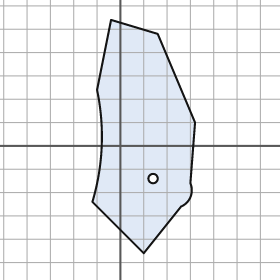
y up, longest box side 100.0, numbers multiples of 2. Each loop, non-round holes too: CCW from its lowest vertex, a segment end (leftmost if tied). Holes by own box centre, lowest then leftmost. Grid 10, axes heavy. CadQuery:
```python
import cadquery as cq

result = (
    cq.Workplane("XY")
    .moveTo(10.0, -46.0)
    .lineTo(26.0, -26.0)
    .threePointArc((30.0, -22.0), (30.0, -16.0))
    .lineTo(32.0, 10.0)
    .lineTo(16.0, 48.0)
    .lineTo(-4.0, 54.0)
    .lineTo(-10.0, 24.0)
    .threePointArc((-8.0, 0.0), (-12.0, -24.0))
    .close()
    .moveTo(14.0, -14.0)
    .circle(2.0)
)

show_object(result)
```